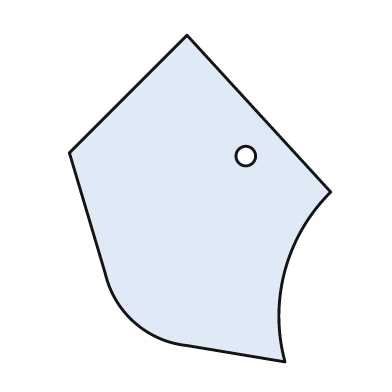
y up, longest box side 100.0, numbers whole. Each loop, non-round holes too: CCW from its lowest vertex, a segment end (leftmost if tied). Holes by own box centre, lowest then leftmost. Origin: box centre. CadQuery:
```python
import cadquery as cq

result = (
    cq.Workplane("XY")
    .moveTo(26.0, -50.0)
    .threePointArc((26.0, -22.0), (40.0, 2.0))
    .lineTo(-4.0, 50.0)
    .lineTo(-40.0, 14.0)
    .lineTo(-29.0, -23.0)
    .threePointArc((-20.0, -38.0), (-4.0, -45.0))
    .close()
    .moveTo(14.0, 13.0)
    .circle(3.0)
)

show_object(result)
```